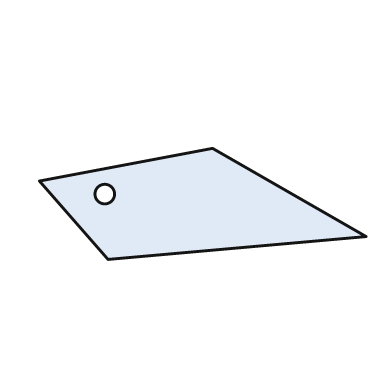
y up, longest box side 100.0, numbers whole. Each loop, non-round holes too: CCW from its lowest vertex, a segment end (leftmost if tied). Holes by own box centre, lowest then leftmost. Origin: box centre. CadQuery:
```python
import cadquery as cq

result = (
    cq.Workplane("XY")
    .moveTo(-29.0, -17.0)
    .lineTo(50.0, -10.0)
    .lineTo(3.0, 17.0)
    .lineTo(-50.0, 7.0)
    .close()
    .moveTo(-30.0, 3.0)
    .circle(3.0)
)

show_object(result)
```